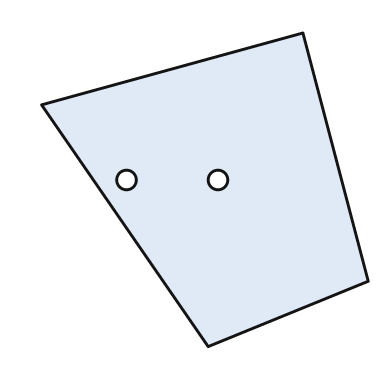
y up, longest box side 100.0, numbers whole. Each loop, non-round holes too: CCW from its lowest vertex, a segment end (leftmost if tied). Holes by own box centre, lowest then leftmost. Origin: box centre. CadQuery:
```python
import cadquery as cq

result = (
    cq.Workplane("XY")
    .moveTo(1.0, -48.0)
    .lineTo(50.0, -28.0)
    .lineTo(30.0, 48.0)
    .lineTo(-50.0, 26.0)
    .close()
    .moveTo(-24.0, 3.0)
    .circle(3.0)
    .moveTo(4.0, 3.0)
    .circle(3.0)
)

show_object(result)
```